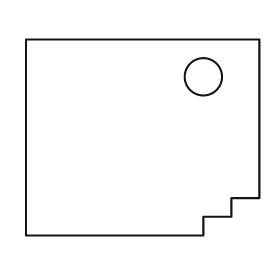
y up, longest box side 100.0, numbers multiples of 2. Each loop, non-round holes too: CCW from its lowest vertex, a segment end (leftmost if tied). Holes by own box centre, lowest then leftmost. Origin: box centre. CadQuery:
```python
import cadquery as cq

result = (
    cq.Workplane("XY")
    .moveTo(-50.0, -42.0)
    .lineTo(26.0, -42.0)
    .lineTo(26.0, -34.0)
    .lineTo(38.0, -34.0)
    .lineTo(38.0, -26.0)
    .lineTo(50.0, -26.0)
    .lineTo(50.0, 42.0)
    .lineTo(-50.0, 42.0)
    .close()
    .moveTo(26.0, 26.0)
    .circle(8.0)
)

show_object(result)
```